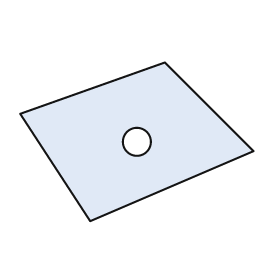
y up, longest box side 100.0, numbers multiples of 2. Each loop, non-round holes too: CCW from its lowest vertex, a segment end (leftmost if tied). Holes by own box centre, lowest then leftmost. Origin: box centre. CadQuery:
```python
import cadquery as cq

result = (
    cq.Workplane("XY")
    .moveTo(-20.0, -34.0)
    .lineTo(50.0, -4.0)
    .lineTo(12.0, 34.0)
    .lineTo(-50.0, 12.0)
    .close()
    .moveTo(0.0, 0.0)
    .circle(6.0)
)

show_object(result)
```